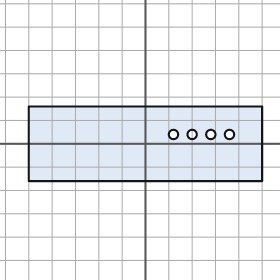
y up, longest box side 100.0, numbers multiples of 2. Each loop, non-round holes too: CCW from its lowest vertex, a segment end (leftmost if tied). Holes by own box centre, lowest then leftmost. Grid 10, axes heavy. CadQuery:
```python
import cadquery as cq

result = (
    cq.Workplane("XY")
    .moveTo(-50.0, -16.0)
    .lineTo(50.0, -16.0)
    .lineTo(50.0, 16.0)
    .lineTo(-50.0, 16.0)
    .close()
    .moveTo(12.0, 4.0)
    .circle(2.0)
    .moveTo(20.0, 4.0)
    .circle(2.0)
    .moveTo(28.0, 4.0)
    .circle(2.0)
    .moveTo(36.0, 4.0)
    .circle(2.0)
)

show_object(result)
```